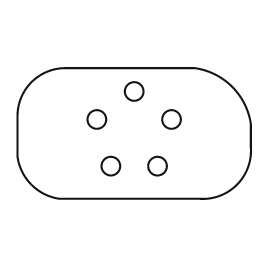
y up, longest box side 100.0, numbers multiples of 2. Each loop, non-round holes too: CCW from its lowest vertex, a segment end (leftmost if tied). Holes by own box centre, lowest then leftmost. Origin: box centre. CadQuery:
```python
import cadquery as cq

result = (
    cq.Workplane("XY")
    .moveTo(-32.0, -28.0)
    .lineTo(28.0, -28.0)
    .threePointArc((44.0, -22.0), (50.0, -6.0))
    .lineTo(50.0, 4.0)
    .threePointArc((42.0, 20.0), (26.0, 28.0))
    .lineTo(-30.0, 28.0)
    .threePointArc((-44.0, 22.0), (-50.0, 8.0))
    .lineTo(-50.0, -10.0)
    .threePointArc((-44.0, -22.0), (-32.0, -28.0))
    .close()
    .moveTo(-10.0, -14.0)
    .circle(4.0)
    .moveTo(10.0, -14.0)
    .circle(4.0)
    .moveTo(-16.0, 6.0)
    .circle(4.0)
    .moveTo(16.0, 6.0)
    .circle(4.0)
    .moveTo(0.0, 18.0)
    .circle(4.0)
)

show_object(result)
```